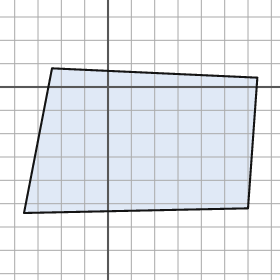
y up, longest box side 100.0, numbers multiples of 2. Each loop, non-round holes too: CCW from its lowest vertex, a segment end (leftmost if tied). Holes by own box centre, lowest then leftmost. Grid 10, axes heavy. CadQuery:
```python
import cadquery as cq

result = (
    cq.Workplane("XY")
    .moveTo(-36.0, -54.0)
    .lineTo(60.0, -52.0)
    .lineTo(64.0, 4.0)
    .lineTo(-24.0, 8.0)
    .close()
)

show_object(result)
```